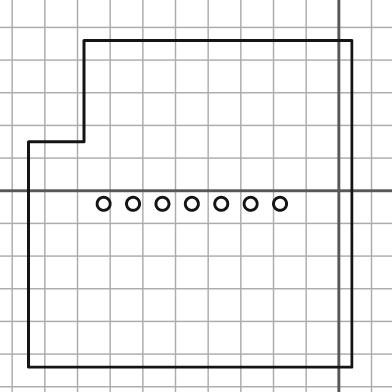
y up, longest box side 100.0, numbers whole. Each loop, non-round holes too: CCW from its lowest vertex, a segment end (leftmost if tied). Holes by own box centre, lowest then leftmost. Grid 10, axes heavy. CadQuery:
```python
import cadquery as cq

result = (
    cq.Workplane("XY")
    .moveTo(-95.0, -54.0)
    .lineTo(4.0, -54.0)
    .lineTo(4.0, 46.0)
    .lineTo(-78.0, 46.0)
    .lineTo(-78.0, 15.0)
    .lineTo(-95.0, 15.0)
    .close()
    .moveTo(-72.0, -4.0)
    .circle(2.0)
    .moveTo(-63.0, -4.0)
    .circle(2.0)
    .moveTo(-54.0, -4.0)
    .circle(2.0)
    .moveTo(-45.0, -4.0)
    .circle(2.0)
    .moveTo(-36.0, -4.0)
    .circle(2.0)
    .moveTo(-27.0, -4.0)
    .circle(2.0)
    .moveTo(-18.0, -4.0)
    .circle(2.0)
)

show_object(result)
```